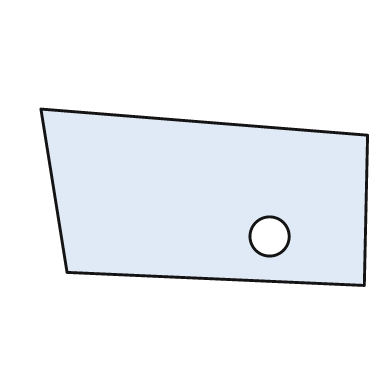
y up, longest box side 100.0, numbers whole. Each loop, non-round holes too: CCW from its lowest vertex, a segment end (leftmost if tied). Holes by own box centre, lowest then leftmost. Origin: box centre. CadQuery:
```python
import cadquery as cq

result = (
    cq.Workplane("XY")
    .moveTo(49.0, -27.0)
    .lineTo(50.0, 19.0)
    .lineTo(-50.0, 27.0)
    .lineTo(-42.0, -23.0)
    .close()
    .moveTo(20.0, -12.0)
    .circle(6.0)
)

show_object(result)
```